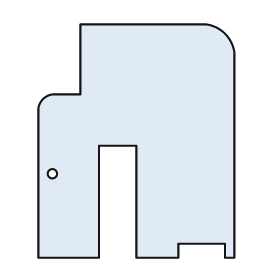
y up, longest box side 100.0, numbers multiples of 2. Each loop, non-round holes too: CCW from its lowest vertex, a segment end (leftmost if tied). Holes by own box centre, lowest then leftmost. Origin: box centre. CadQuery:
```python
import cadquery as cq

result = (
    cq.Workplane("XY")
    .moveTo(-42.0, -50.0)
    .lineTo(-16.0, -50.0)
    .lineTo(-16.0, -2.0)
    .lineTo(0.0, -2.0)
    .lineTo(0.0, -50.0)
    .lineTo(18.0, -50.0)
    .lineTo(18.0, -44.0)
    .lineTo(38.0, -44.0)
    .lineTo(38.0, -50.0)
    .lineTo(42.0, -50.0)
    .lineTo(42.0, 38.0)
    .threePointArc((38.0, 46.0), (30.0, 50.0))
    .lineTo(-24.0, 50.0)
    .lineTo(-24.0, 20.0)
    .lineTo(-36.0, 20.0)
    .threePointArc((-40.0, 18.0), (-42.0, 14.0))
    .close()
    .moveTo(-36.0, -14.0)
    .circle(2.0)
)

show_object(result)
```